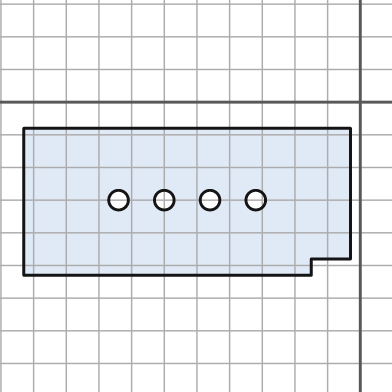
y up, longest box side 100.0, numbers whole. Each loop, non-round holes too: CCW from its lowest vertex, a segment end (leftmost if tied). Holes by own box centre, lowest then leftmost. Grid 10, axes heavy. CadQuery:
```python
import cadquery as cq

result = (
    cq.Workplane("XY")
    .moveTo(-103.0, -53.0)
    .lineTo(-15.0, -53.0)
    .lineTo(-15.0, -48.0)
    .lineTo(-3.0, -48.0)
    .lineTo(-3.0, -8.0)
    .lineTo(-103.0, -8.0)
    .close()
    .moveTo(-74.0, -30.0)
    .circle(3.0)
    .moveTo(-60.0, -30.0)
    .circle(3.0)
    .moveTo(-46.0, -30.0)
    .circle(3.0)
    .moveTo(-32.0, -30.0)
    .circle(3.0)
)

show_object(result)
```